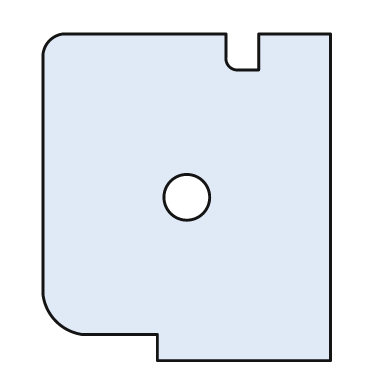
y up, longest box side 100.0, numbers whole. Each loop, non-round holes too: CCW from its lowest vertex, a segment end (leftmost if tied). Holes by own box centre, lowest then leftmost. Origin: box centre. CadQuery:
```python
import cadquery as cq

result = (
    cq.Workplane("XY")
    .moveTo(-9.0, -50.0)
    .lineTo(44.0, -50.0)
    .lineTo(44.0, 50.0)
    .lineTo(22.0, 50.0)
    .lineTo(22.0, 39.0)
    .lineTo(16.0, 39.0)
    .threePointArc((13.0, 40.0), (12.0, 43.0))
    .lineTo(12.0, 50.0)
    .lineTo(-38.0, 50.0)
    .threePointArc((-42.0, 48.0), (-44.0, 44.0))
    .lineTo(-44.0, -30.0)
    .threePointArc((-40.0, -38.0), (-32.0, -42.0))
    .lineTo(-9.0, -42.0)
    .close()
    .moveTo(0.0, 0.0)
    .circle(7.0)
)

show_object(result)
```